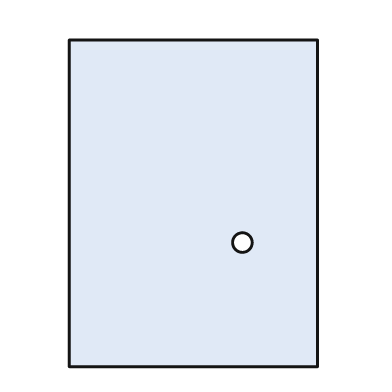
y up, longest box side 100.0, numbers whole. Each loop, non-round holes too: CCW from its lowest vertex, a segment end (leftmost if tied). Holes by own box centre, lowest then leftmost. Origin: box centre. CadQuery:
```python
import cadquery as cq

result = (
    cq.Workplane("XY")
    .moveTo(-38.0, -50.0)
    .lineTo(38.0, -50.0)
    .lineTo(38.0, 50.0)
    .lineTo(-38.0, 50.0)
    .close()
    .moveTo(15.0, -12.0)
    .circle(3.0)
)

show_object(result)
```